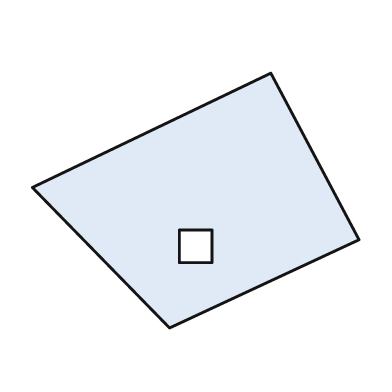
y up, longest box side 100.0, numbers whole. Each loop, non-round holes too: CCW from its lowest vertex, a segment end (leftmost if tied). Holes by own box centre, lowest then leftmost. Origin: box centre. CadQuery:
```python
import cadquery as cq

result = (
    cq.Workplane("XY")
    .moveTo(-8.0, -39.0)
    .lineTo(50.0, -12.0)
    .lineTo(23.0, 39.0)
    .lineTo(-50.0, 4.0)
    .close()
    .moveTo(-5.0, -19.0)
    .lineTo(5.0, -19.0)
    .lineTo(5.0, -9.0)
    .lineTo(-5.0, -9.0)
    .close()
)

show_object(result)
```